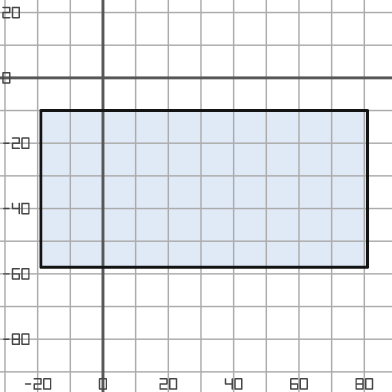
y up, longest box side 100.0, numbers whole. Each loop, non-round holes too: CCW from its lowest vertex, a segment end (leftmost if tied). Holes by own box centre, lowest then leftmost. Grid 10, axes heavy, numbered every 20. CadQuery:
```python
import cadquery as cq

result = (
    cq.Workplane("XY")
    .moveTo(-19.0, -58.0)
    .lineTo(81.0, -58.0)
    .lineTo(81.0, -10.0)
    .lineTo(-19.0, -10.0)
    .close()
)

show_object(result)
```